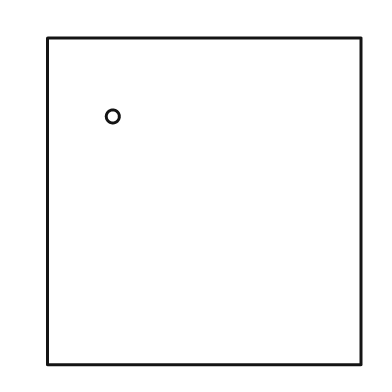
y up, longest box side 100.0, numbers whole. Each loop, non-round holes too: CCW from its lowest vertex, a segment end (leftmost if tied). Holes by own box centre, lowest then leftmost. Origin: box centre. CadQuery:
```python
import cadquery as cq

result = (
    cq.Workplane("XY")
    .moveTo(-48.0, -50.0)
    .lineTo(48.0, -50.0)
    .lineTo(48.0, 50.0)
    .lineTo(-48.0, 50.0)
    .close()
    .moveTo(-28.0, 26.0)
    .circle(2.0)
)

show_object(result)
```